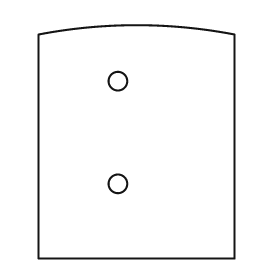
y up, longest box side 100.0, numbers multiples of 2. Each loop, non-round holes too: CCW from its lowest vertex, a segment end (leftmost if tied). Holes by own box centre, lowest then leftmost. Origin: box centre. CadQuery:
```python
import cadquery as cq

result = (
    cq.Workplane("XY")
    .moveTo(-42.0, -50.0)
    .lineTo(42.0, -50.0)
    .lineTo(42.0, 46.0)
    .threePointArc((0.0, 50.0), (-42.0, 46.0))
    .close()
    .moveTo(-8.0, -18.0)
    .circle(4.0)
    .moveTo(-8.0, 26.0)
    .circle(4.0)
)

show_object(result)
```